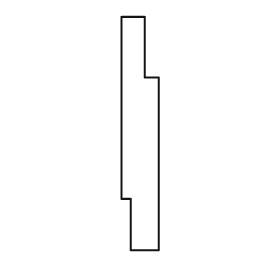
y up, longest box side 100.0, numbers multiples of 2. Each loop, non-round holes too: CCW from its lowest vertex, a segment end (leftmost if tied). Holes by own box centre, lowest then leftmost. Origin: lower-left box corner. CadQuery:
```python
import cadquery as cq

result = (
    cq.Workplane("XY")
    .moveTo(4.0, 0.0)
    .lineTo(16.0, 0.0)
    .lineTo(16.0, 74.0)
    .lineTo(10.0, 74.0)
    .lineTo(10.0, 100.0)
    .lineTo(0.0, 100.0)
    .lineTo(0.0, 22.0)
    .lineTo(4.0, 22.0)
    .close()
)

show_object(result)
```